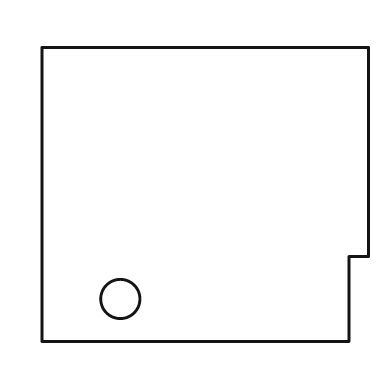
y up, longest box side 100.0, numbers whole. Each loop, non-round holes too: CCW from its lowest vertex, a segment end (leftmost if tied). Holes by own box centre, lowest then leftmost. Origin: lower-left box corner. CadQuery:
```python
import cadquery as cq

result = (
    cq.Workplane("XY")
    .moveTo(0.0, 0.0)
    .lineTo(94.0, 0.0)
    .lineTo(94.0, 26.0)
    .lineTo(100.0, 26.0)
    .lineTo(100.0, 90.0)
    .lineTo(0.0, 90.0)
    .close()
    .moveTo(24.0, 13.0)
    .circle(6.0)
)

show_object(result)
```